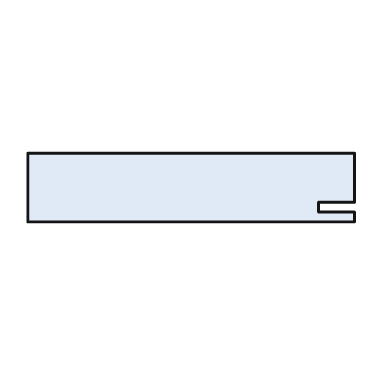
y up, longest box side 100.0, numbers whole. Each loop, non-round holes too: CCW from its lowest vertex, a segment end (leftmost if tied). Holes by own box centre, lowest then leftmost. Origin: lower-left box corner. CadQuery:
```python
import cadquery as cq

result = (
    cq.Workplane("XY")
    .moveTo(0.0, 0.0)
    .lineTo(100.0, 0.0)
    .lineTo(100.0, 3.0)
    .lineTo(89.0, 3.0)
    .lineTo(89.0, 6.0)
    .lineTo(100.0, 6.0)
    .lineTo(100.0, 21.0)
    .lineTo(0.0, 21.0)
    .close()
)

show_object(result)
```